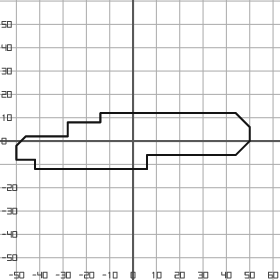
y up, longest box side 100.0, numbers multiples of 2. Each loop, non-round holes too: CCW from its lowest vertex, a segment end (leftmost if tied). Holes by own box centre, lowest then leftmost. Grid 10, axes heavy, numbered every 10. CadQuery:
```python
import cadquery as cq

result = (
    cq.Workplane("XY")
    .moveTo(-42.0, -12.0)
    .lineTo(6.0, -12.0)
    .lineTo(6.0, -6.0)
    .lineTo(44.0, -6.0)
    .lineTo(50.0, 0.0)
    .lineTo(50.0, 6.0)
    .lineTo(44.0, 12.0)
    .lineTo(-14.0, 12.0)
    .lineTo(-14.0, 8.0)
    .lineTo(-28.0, 8.0)
    .lineTo(-28.0, 2.0)
    .lineTo(-46.0, 2.0)
    .lineTo(-50.0, -2.0)
    .lineTo(-50.0, -8.0)
    .lineTo(-42.0, -8.0)
    .close()
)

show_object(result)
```